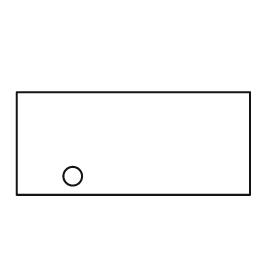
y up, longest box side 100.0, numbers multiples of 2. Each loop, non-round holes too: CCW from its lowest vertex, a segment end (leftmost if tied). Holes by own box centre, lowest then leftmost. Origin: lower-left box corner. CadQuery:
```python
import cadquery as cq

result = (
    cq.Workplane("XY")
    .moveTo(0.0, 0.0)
    .lineTo(100.0, 0.0)
    .lineTo(100.0, 44.0)
    .lineTo(0.0, 44.0)
    .close()
    .moveTo(24.0, 8.0)
    .circle(4.0)
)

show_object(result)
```